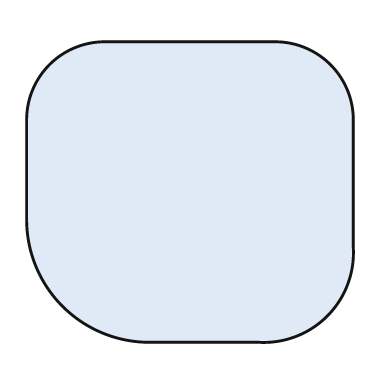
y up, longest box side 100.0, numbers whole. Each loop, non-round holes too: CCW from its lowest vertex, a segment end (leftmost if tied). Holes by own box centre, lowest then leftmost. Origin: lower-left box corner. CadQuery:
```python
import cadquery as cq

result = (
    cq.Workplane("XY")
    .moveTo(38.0, 0.0)
    .lineTo(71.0, 0.0)
    .threePointArc((92.0, 8.0), (100.0, 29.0))
    .lineTo(100.0, 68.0)
    .threePointArc((93.0, 85.0), (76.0, 92.0))
    .lineTo(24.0, 92.0)
    .threePointArc((7.0, 85.0), (0.0, 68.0))
    .lineTo(0.0, 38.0)
    .threePointArc((11.0, 11.0), (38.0, 0.0))
    .close()
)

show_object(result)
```